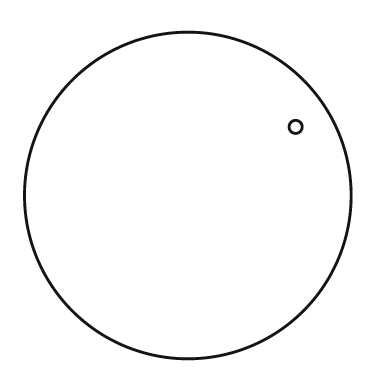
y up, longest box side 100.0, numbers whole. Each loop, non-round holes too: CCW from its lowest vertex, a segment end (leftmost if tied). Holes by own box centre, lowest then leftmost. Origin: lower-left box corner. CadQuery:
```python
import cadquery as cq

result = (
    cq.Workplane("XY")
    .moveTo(50.0, 50.0)
    .circle(50.0)
    .moveTo(83.0, 71.0)
    .circle(2.0)
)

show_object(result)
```